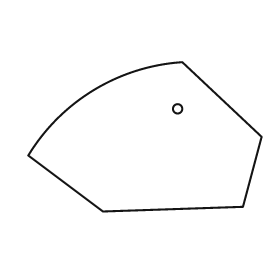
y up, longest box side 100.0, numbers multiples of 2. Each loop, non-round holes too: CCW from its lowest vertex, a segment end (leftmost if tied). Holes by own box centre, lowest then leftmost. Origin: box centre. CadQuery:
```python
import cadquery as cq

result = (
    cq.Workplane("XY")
    .moveTo(-18.0, -32.0)
    .lineTo(42.0, -30.0)
    .lineTo(50.0, 0.0)
    .lineTo(16.0, 32.0)
    .threePointArc((-22.0, 20.0), (-50.0, -8.0))
    .close()
    .moveTo(14.0, 12.0)
    .circle(2.0)
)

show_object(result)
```